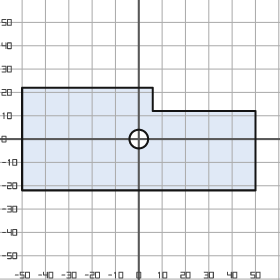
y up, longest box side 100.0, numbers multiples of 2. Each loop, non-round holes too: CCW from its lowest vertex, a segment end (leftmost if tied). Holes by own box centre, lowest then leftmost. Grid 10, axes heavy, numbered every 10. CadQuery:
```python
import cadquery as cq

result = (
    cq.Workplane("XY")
    .moveTo(-50.0, -22.0)
    .lineTo(50.0, -22.0)
    .lineTo(50.0, 12.0)
    .lineTo(6.0, 12.0)
    .lineTo(6.0, 22.0)
    .lineTo(-50.0, 22.0)
    .close()
    .moveTo(0.0, 0.0)
    .circle(4.0)
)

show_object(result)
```